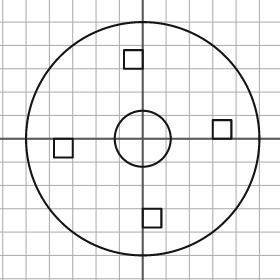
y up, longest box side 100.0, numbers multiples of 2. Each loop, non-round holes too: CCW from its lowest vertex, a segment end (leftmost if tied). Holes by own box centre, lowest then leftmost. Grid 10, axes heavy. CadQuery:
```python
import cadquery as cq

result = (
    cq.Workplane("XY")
    .moveTo(0.0, 0.0)
    .circle(50.0)
    .moveTo(0.0, -38.0)
    .lineTo(8.0, -38.0)
    .lineTo(8.0, -30.0)
    .lineTo(0.0, -30.0)
    .close()
    .moveTo(-38.0, -8.0)
    .lineTo(-30.0, -8.0)
    .lineTo(-30.0, 0.0)
    .lineTo(-38.0, 0.0)
    .close()
    .moveTo(0.0, 0.0)
    .circle(12.0)
    .moveTo(30.0, 0.0)
    .lineTo(38.0, 0.0)
    .lineTo(38.0, 8.0)
    .lineTo(30.0, 8.0)
    .close()
    .moveTo(-8.0, 30.0)
    .lineTo(0.0, 30.0)
    .lineTo(0.0, 38.0)
    .lineTo(-8.0, 38.0)
    .close()
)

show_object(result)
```